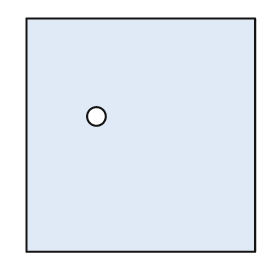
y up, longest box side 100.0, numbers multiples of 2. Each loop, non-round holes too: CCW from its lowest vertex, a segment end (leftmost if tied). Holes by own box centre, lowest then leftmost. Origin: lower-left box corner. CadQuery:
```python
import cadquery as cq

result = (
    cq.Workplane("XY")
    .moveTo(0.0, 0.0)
    .lineTo(98.0, 0.0)
    .lineTo(98.0, 100.0)
    .lineTo(0.0, 100.0)
    .close()
    .moveTo(30.0, 58.0)
    .circle(4.0)
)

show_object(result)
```